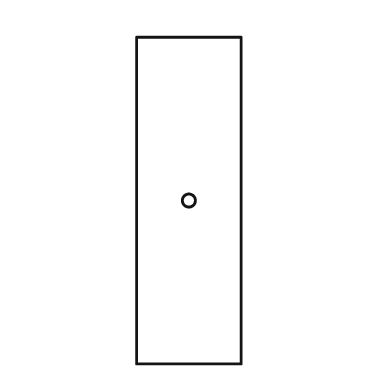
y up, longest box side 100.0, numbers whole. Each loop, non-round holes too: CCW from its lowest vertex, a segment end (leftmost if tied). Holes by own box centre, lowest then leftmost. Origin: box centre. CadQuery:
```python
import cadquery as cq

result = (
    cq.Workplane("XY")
    .moveTo(-16.0, -50.0)
    .lineTo(16.0, -50.0)
    .lineTo(16.0, 50.0)
    .lineTo(-16.0, 50.0)
    .close()
    .moveTo(0.0, 0.0)
    .circle(2.0)
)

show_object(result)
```